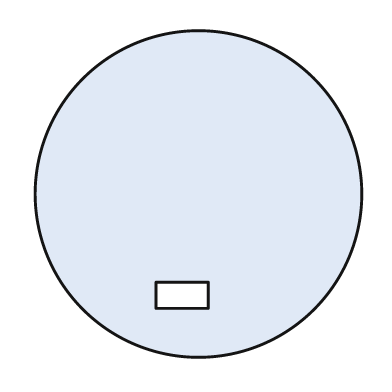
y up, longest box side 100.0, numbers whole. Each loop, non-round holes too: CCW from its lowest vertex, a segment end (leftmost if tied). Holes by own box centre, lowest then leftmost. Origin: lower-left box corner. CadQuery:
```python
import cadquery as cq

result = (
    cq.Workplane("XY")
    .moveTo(50.0, 50.0)
    .circle(50.0)
    .moveTo(37.0, 15.0)
    .lineTo(53.0, 15.0)
    .lineTo(53.0, 23.0)
    .lineTo(37.0, 23.0)
    .close()
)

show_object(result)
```